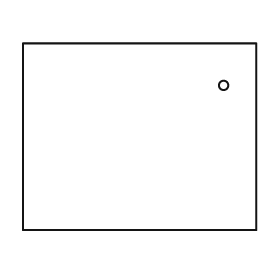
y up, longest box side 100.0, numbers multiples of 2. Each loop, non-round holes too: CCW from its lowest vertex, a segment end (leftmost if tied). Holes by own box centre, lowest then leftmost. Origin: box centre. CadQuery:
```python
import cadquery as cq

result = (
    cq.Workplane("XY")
    .moveTo(-50.0, -40.0)
    .lineTo(50.0, -40.0)
    .lineTo(50.0, 40.0)
    .lineTo(-50.0, 40.0)
    .close()
    .moveTo(36.0, 22.0)
    .circle(2.0)
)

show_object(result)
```